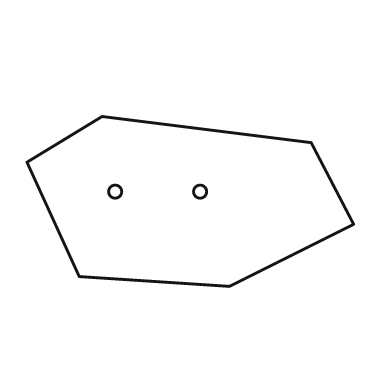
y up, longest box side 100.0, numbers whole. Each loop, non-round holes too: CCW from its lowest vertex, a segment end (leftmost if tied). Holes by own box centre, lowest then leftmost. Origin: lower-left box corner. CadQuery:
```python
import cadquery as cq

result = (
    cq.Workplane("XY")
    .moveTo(62.0, 0.0)
    .lineTo(100.0, 19.0)
    .lineTo(87.0, 44.0)
    .lineTo(23.0, 52.0)
    .lineTo(0.0, 38.0)
    .lineTo(16.0, 3.0)
    .close()
    .moveTo(27.0, 29.0)
    .circle(2.0)
    .moveTo(53.0, 29.0)
    .circle(2.0)
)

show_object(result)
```